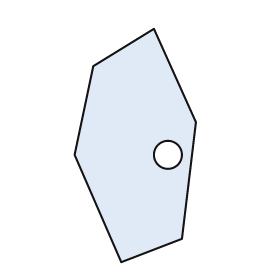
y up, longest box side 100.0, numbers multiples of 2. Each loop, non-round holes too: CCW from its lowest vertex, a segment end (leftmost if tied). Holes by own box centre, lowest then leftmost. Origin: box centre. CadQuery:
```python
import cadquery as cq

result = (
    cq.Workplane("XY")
    .moveTo(-6.0, -50.0)
    .lineTo(20.0, -40.0)
    .lineTo(26.0, 10.0)
    .lineTo(8.0, 50.0)
    .lineTo(-18.0, 34.0)
    .lineTo(-26.0, -4.0)
    .close()
    .moveTo(14.0, -4.0)
    .circle(6.0)
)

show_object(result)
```